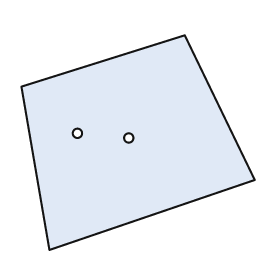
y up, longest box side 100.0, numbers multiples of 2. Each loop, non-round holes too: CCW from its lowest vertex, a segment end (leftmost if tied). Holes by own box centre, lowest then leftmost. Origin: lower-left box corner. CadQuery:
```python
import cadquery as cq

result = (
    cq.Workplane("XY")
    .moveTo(12.0, 0.0)
    .lineTo(100.0, 30.0)
    .lineTo(70.0, 92.0)
    .lineTo(0.0, 70.0)
    .close()
    .moveTo(46.0, 48.0)
    .circle(2.0)
    .moveTo(24.0, 50.0)
    .circle(2.0)
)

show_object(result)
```